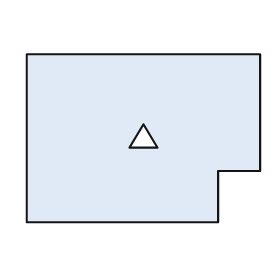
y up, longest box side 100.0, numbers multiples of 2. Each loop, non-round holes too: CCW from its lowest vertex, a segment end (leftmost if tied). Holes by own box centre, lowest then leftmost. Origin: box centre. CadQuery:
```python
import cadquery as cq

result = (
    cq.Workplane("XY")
    .moveTo(-50.0, -36.0)
    .lineTo(32.0, -36.0)
    .lineTo(32.0, -14.0)
    .lineTo(50.0, -14.0)
    .lineTo(50.0, 36.0)
    .lineTo(-50.0, 36.0)
    .close()
    .moveTo(-6.0, -4.0)
    .lineTo(6.0, -4.0)
    .lineTo(0.0, 6.0)
    .close()
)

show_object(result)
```